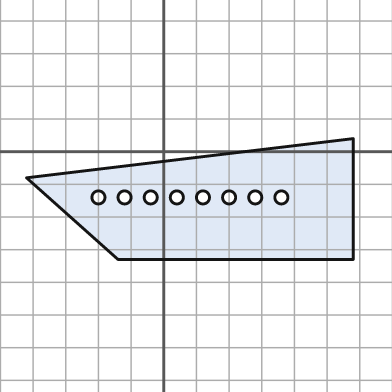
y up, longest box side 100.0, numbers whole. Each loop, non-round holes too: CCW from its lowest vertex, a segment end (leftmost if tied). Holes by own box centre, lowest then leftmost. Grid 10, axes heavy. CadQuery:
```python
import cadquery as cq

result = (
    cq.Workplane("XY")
    .moveTo(-14.0, -33.0)
    .lineTo(58.0, -33.0)
    .lineTo(58.0, 4.0)
    .lineTo(-42.0, -8.0)
    .close()
    .moveTo(-20.0, -14.0)
    .circle(2.0)
    .moveTo(-12.0, -14.0)
    .circle(2.0)
    .moveTo(-4.0, -14.0)
    .circle(2.0)
    .moveTo(4.0, -14.0)
    .circle(2.0)
    .moveTo(12.0, -14.0)
    .circle(2.0)
    .moveTo(20.0, -14.0)
    .circle(2.0)
    .moveTo(28.0, -14.0)
    .circle(2.0)
    .moveTo(36.0, -14.0)
    .circle(2.0)
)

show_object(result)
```